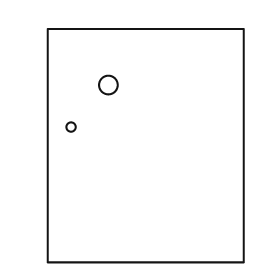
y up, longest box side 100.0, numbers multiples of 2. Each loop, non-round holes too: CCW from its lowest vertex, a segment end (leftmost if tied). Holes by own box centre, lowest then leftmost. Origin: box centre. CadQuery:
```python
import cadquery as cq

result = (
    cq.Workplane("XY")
    .moveTo(-42.0, -50.0)
    .lineTo(42.0, -50.0)
    .lineTo(42.0, 50.0)
    .lineTo(-42.0, 50.0)
    .close()
    .moveTo(-32.0, 8.0)
    .circle(2.0)
    .moveTo(-16.0, 26.0)
    .circle(4.0)
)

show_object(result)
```